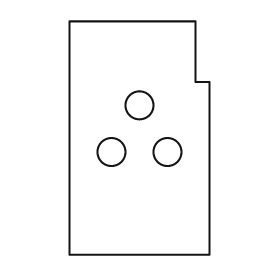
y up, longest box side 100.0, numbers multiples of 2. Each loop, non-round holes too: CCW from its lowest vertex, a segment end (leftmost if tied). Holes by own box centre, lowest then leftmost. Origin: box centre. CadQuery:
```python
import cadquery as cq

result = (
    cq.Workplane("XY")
    .moveTo(-30.0, -50.0)
    .lineTo(30.0, -50.0)
    .lineTo(30.0, 24.0)
    .lineTo(24.0, 24.0)
    .lineTo(24.0, 50.0)
    .lineTo(-30.0, 50.0)
    .close()
    .moveTo(-12.0, -6.0)
    .circle(6.0)
    .moveTo(12.0, -6.0)
    .circle(6.0)
    .moveTo(0.0, 14.0)
    .circle(6.0)
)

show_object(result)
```